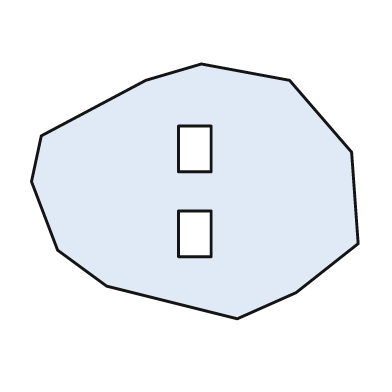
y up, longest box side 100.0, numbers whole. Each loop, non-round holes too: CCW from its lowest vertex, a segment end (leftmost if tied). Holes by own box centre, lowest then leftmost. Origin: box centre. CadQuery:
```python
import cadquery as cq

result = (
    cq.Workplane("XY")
    .moveTo(13.0, -39.0)
    .lineTo(31.0, -31.0)
    .lineTo(50.0, -16.0)
    .lineTo(48.0, 12.0)
    .lineTo(29.0, 34.0)
    .lineTo(2.0, 39.0)
    .lineTo(-15.0, 34.0)
    .lineTo(-47.0, 17.0)
    .lineTo(-50.0, 3.0)
    .lineTo(-42.0, -18.0)
    .lineTo(-27.0, -29.0)
    .close()
    .moveTo(-5.0, -20.0)
    .lineTo(5.0, -20.0)
    .lineTo(5.0, -6.0)
    .lineTo(-5.0, -6.0)
    .close()
    .moveTo(-5.0, 6.0)
    .lineTo(5.0, 6.0)
    .lineTo(5.0, 20.0)
    .lineTo(-5.0, 20.0)
    .close()
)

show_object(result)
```